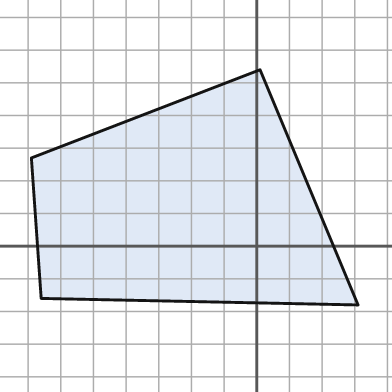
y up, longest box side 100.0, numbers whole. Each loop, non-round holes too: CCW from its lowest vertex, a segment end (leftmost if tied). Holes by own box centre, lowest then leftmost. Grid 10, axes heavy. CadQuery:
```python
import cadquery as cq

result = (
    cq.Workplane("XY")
    .moveTo(31.0, -18.0)
    .lineTo(1.0, 54.0)
    .lineTo(-69.0, 27.0)
    .lineTo(-66.0, -16.0)
    .close()
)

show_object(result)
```